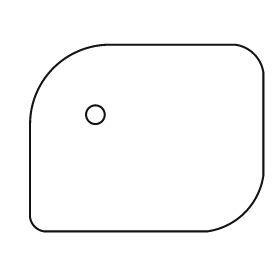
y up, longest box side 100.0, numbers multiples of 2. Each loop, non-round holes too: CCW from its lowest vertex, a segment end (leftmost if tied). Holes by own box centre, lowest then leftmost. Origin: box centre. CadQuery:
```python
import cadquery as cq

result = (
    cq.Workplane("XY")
    .moveTo(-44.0, -40.0)
    .lineTo(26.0, -40.0)
    .threePointArc((42.0, -32.0), (50.0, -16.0))
    .lineTo(50.0, 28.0)
    .threePointArc((46.0, 36.0), (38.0, 40.0))
    .lineTo(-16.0, 40.0)
    .threePointArc((-40.0, 30.0), (-50.0, 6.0))
    .lineTo(-50.0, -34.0)
    .threePointArc((-48.0, -38.0), (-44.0, -40.0))
    .close()
    .moveTo(-22.0, 10.0)
    .circle(4.0)
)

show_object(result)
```